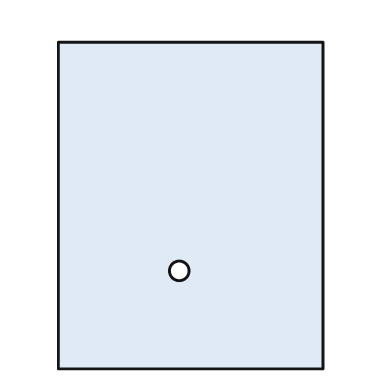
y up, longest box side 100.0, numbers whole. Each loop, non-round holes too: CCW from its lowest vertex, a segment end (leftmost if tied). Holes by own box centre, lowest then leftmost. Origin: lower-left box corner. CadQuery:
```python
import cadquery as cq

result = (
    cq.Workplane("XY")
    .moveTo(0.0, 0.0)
    .lineTo(81.0, 0.0)
    .lineTo(81.0, 100.0)
    .lineTo(0.0, 100.0)
    .close()
    .moveTo(37.0, 30.0)
    .circle(3.0)
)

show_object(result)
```